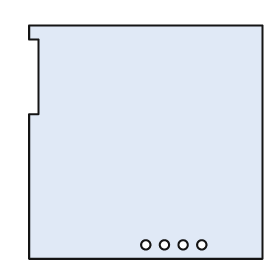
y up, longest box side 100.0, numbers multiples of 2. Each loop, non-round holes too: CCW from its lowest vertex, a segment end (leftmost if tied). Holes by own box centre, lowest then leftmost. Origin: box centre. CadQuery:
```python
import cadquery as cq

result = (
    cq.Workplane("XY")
    .moveTo(-50.0, -50.0)
    .lineTo(50.0, -50.0)
    .lineTo(50.0, 50.0)
    .lineTo(-50.0, 50.0)
    .lineTo(-50.0, 44.0)
    .lineTo(-46.0, 44.0)
    .lineTo(-46.0, 12.0)
    .lineTo(-50.0, 12.0)
    .close()
    .moveTo(0.0, -44.0)
    .circle(2.0)
    .moveTo(8.0, -44.0)
    .circle(2.0)
    .moveTo(16.0, -44.0)
    .circle(2.0)
    .moveTo(24.0, -44.0)
    .circle(2.0)
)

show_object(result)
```